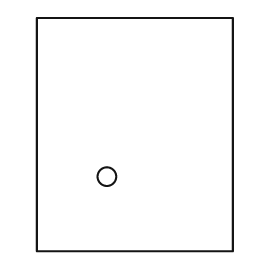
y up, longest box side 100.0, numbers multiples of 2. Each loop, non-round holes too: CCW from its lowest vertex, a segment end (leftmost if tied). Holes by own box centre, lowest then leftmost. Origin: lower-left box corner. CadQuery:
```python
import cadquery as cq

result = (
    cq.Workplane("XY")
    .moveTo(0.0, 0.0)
    .lineTo(84.0, 0.0)
    .lineTo(84.0, 100.0)
    .lineTo(0.0, 100.0)
    .close()
    .moveTo(30.0, 32.0)
    .circle(4.0)
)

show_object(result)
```